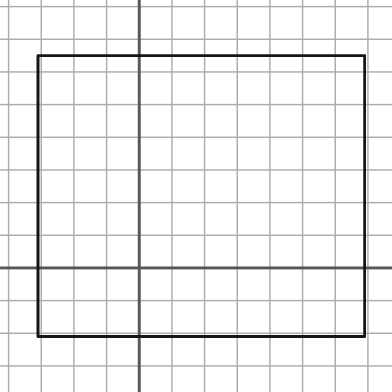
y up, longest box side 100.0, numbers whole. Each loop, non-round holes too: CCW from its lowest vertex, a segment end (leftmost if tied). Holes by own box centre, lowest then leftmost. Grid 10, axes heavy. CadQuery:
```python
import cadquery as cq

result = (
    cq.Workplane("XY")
    .moveTo(-31.0, -21.0)
    .lineTo(69.0, -21.0)
    .lineTo(69.0, 65.0)
    .lineTo(-31.0, 65.0)
    .close()
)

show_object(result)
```